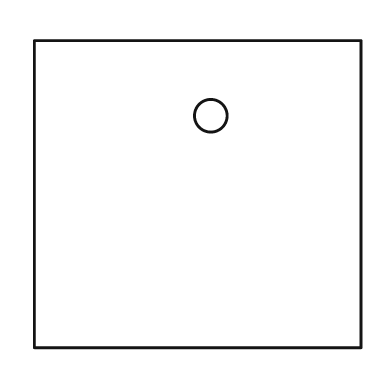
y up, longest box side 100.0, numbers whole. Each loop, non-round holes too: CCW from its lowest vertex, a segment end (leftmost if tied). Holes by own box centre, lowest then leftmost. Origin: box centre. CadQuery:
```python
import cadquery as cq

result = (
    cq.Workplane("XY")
    .moveTo(-50.0, -47.0)
    .lineTo(50.0, -47.0)
    .lineTo(50.0, 47.0)
    .lineTo(-50.0, 47.0)
    .close()
    .moveTo(4.0, 24.0)
    .circle(5.0)
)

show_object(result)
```